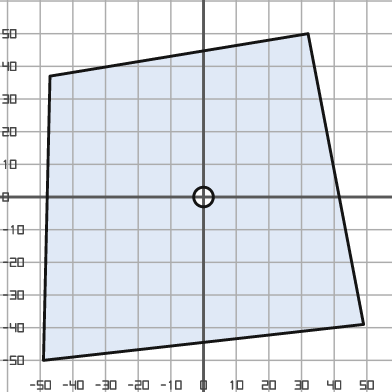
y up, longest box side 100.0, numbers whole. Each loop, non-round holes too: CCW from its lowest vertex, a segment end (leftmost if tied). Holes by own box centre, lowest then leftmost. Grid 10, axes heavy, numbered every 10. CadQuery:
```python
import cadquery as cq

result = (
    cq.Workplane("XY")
    .moveTo(-49.0, -50.0)
    .lineTo(49.0, -39.0)
    .lineTo(32.0, 50.0)
    .lineTo(-47.0, 37.0)
    .close()
    .moveTo(0.0, 0.0)
    .circle(3.0)
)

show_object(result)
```